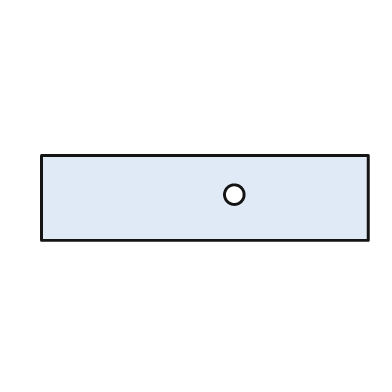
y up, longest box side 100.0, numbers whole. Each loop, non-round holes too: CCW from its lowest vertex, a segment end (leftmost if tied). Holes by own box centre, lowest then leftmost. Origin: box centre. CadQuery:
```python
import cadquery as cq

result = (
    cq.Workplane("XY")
    .moveTo(-50.0, -13.0)
    .lineTo(50.0, -13.0)
    .lineTo(50.0, 13.0)
    .lineTo(-50.0, 13.0)
    .close()
    .moveTo(9.0, 1.0)
    .circle(3.0)
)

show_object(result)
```